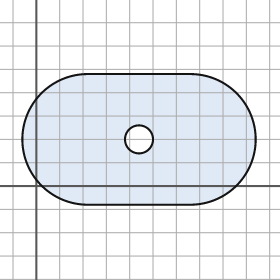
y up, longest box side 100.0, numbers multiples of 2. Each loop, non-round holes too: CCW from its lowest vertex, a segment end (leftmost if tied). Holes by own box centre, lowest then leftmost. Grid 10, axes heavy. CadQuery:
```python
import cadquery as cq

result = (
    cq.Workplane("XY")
    .moveTo(22.0, -8.0)
    .lineTo(66.0, -8.0)
    .threePointArc((94.0, 20.0), (66.0, 48.0))
    .lineTo(22.0, 48.0)
    .threePointArc((-6.0, 20.0), (22.0, -8.0))
    .close()
    .moveTo(44.0, 20.0)
    .circle(6.0)
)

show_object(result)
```